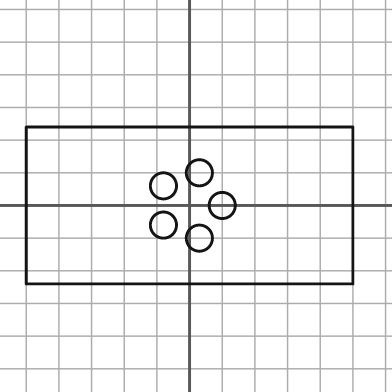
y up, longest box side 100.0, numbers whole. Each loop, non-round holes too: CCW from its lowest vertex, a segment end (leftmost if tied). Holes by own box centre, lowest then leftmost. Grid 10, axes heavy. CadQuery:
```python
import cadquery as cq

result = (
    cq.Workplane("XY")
    .moveTo(-50.0, -24.0)
    .lineTo(50.0, -24.0)
    .lineTo(50.0, 24.0)
    .lineTo(-50.0, 24.0)
    .close()
    .moveTo(3.0, -10.0)
    .circle(4.0)
    .moveTo(-8.0, -6.0)
    .circle(4.0)
    .moveTo(10.0, 0.0)
    .circle(4.0)
    .moveTo(-8.0, 6.0)
    .circle(4.0)
    .moveTo(3.0, 10.0)
    .circle(4.0)
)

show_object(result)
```